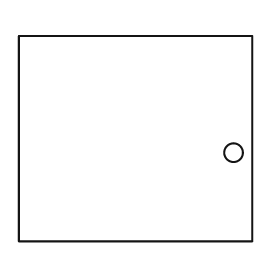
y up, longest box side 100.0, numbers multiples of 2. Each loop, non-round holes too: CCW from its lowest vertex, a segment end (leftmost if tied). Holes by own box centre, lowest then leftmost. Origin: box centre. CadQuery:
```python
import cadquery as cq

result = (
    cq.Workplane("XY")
    .moveTo(-50.0, -44.0)
    .lineTo(50.0, -44.0)
    .lineTo(50.0, 44.0)
    .lineTo(-50.0, 44.0)
    .close()
    .moveTo(42.0, -6.0)
    .circle(4.0)
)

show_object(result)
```